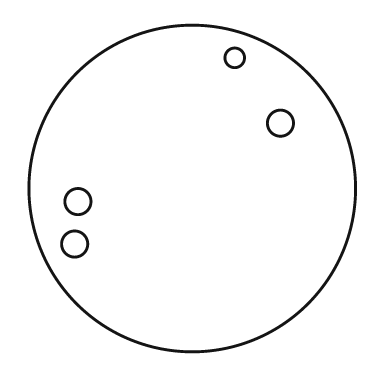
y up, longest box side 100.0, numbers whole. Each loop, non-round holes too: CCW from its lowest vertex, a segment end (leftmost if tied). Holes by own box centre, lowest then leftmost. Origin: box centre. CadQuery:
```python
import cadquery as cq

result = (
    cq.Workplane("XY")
    .moveTo(0.0, 0.0)
    .circle(50.0)
    .moveTo(-36.0, -17.0)
    .circle(4.0)
    .moveTo(-35.0, -4.0)
    .circle(4.0)
    .moveTo(27.0, 20.0)
    .circle(4.0)
    .moveTo(13.0, 40.0)
    .circle(3.0)
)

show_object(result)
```